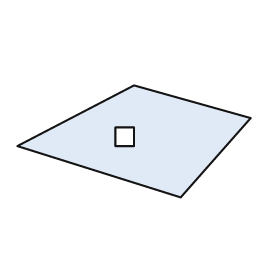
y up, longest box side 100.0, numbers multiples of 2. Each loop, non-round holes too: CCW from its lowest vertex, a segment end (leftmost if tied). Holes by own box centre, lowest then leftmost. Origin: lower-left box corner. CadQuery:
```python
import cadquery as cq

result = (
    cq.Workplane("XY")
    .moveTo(70.0, 0.0)
    .lineTo(100.0, 34.0)
    .lineTo(50.0, 48.0)
    .lineTo(0.0, 22.0)
    .close()
    .moveTo(42.0, 22.0)
    .lineTo(50.0, 22.0)
    .lineTo(50.0, 30.0)
    .lineTo(42.0, 30.0)
    .close()
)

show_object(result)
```